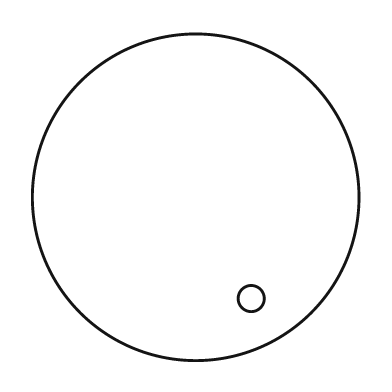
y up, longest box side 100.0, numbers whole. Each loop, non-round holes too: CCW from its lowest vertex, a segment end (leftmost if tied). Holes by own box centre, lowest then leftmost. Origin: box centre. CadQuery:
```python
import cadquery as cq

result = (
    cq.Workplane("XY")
    .moveTo(0.0, 0.0)
    .circle(50.0)
    .moveTo(17.0, -31.0)
    .circle(4.0)
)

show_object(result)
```